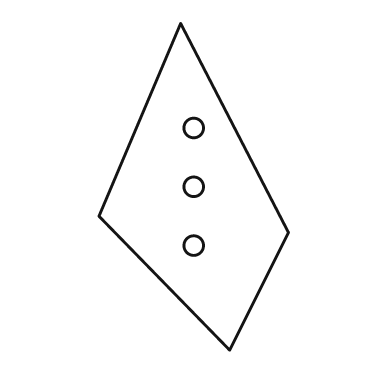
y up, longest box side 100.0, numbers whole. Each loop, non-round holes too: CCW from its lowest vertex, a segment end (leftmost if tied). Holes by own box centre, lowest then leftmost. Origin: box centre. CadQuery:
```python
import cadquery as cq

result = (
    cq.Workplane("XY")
    .moveTo(11.0, -50.0)
    .lineTo(29.0, -14.0)
    .lineTo(-4.0, 50.0)
    .lineTo(-29.0, -9.0)
    .close()
    .moveTo(0.0, -18.0)
    .circle(3.0)
    .moveTo(0.0, 0.0)
    .circle(3.0)
    .moveTo(0.0, 18.0)
    .circle(3.0)
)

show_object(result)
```